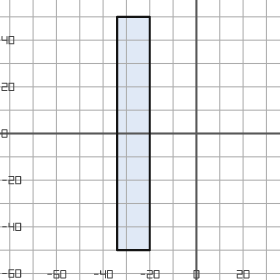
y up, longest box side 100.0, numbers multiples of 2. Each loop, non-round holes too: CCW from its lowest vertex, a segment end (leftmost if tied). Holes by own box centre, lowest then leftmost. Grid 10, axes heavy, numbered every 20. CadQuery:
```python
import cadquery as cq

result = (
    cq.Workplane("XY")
    .moveTo(-34.0, -50.0)
    .lineTo(-20.0, -50.0)
    .lineTo(-20.0, 50.0)
    .lineTo(-34.0, 50.0)
    .close()
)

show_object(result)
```